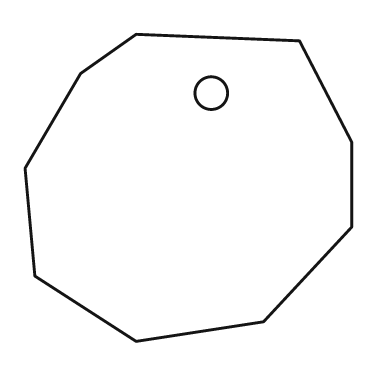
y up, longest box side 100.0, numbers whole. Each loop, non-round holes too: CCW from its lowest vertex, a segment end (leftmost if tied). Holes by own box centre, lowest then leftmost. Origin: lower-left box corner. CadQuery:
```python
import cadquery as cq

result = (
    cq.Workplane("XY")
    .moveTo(34.0, 0.0)
    .lineTo(73.0, 6.0)
    .lineTo(100.0, 35.0)
    .lineTo(100.0, 61.0)
    .lineTo(84.0, 92.0)
    .lineTo(34.0, 94.0)
    .lineTo(17.0, 82.0)
    .lineTo(0.0, 53.0)
    .lineTo(3.0, 20.0)
    .close()
    .moveTo(57.0, 76.0)
    .circle(5.0)
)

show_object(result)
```